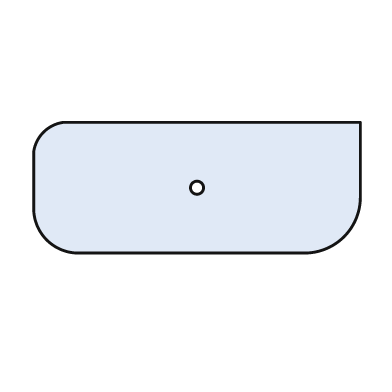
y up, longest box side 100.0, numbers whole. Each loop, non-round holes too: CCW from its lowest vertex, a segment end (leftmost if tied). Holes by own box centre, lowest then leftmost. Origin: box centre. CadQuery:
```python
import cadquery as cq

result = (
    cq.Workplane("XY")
    .moveTo(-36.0, -20.0)
    .lineTo(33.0, -20.0)
    .threePointArc((45.0, -15.0), (50.0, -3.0))
    .lineTo(50.0, 20.0)
    .lineTo(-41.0, 20.0)
    .threePointArc((-47.0, 17.0), (-50.0, 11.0))
    .lineTo(-50.0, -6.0)
    .threePointArc((-46.0, -16.0), (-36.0, -20.0))
    .close()
    .moveTo(0.0, 0.0)
    .circle(2.0)
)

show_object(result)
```